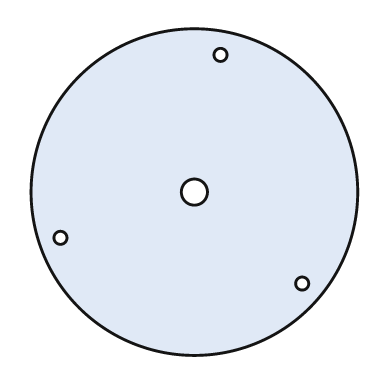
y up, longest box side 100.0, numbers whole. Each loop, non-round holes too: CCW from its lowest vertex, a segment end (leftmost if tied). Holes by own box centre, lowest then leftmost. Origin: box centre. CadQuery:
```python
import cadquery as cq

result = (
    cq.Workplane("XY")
    .moveTo(0.0, 0.0)
    .circle(50.0)
    .moveTo(33.0, -28.0)
    .circle(2.0)
    .moveTo(-41.0, -14.0)
    .circle(2.0)
    .moveTo(0.0, 0.0)
    .circle(4.0)
    .moveTo(8.0, 42.0)
    .circle(2.0)
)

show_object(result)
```